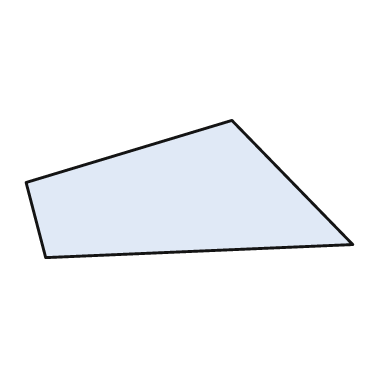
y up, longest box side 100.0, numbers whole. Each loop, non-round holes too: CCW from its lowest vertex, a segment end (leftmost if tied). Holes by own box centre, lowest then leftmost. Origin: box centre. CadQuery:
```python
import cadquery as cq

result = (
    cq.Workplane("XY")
    .moveTo(-44.0, -21.0)
    .lineTo(50.0, -17.0)
    .lineTo(13.0, 21.0)
    .lineTo(-50.0, 2.0)
    .close()
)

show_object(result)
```